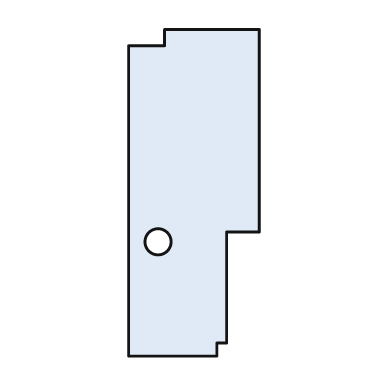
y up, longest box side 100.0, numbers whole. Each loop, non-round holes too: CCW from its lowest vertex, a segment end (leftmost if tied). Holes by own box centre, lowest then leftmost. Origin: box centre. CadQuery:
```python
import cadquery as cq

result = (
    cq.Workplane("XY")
    .moveTo(-20.0, -50.0)
    .lineTo(7.0, -50.0)
    .lineTo(7.0, -46.0)
    .lineTo(10.0, -46.0)
    .lineTo(10.0, -12.0)
    .lineTo(20.0, -12.0)
    .lineTo(20.0, 50.0)
    .lineTo(-9.0, 50.0)
    .lineTo(-9.0, 45.0)
    .lineTo(-20.0, 45.0)
    .close()
    .moveTo(-11.0, -15.0)
    .circle(4.0)
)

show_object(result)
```